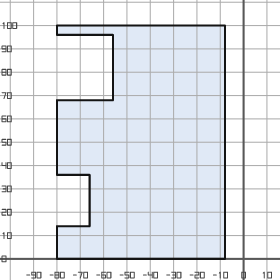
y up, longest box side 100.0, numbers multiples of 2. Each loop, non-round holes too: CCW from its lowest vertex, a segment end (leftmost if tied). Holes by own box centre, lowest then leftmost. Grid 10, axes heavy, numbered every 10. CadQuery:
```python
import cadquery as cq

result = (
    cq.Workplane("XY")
    .moveTo(-80.0, 0.0)
    .lineTo(-8.0, 0.0)
    .lineTo(-8.0, 100.0)
    .lineTo(-80.0, 100.0)
    .lineTo(-80.0, 96.0)
    .lineTo(-56.0, 96.0)
    .lineTo(-56.0, 68.0)
    .lineTo(-80.0, 68.0)
    .lineTo(-80.0, 36.0)
    .lineTo(-66.0, 36.0)
    .lineTo(-66.0, 14.0)
    .lineTo(-80.0, 14.0)
    .close()
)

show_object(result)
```